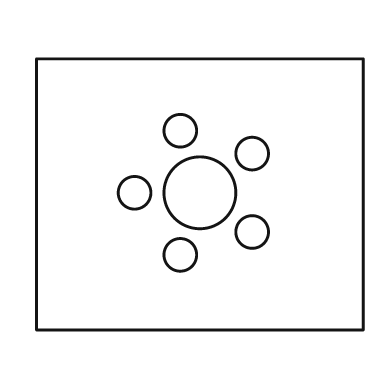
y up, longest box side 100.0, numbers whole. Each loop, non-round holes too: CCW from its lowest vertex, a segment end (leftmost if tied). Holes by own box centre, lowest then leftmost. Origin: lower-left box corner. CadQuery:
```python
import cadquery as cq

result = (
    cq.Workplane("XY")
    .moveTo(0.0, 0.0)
    .lineTo(100.0, 0.0)
    .lineTo(100.0, 83.0)
    .lineTo(0.0, 83.0)
    .close()
    .moveTo(44.0, 23.0)
    .circle(5.0)
    .moveTo(66.0, 30.0)
    .circle(5.0)
    .moveTo(30.0, 42.0)
    .circle(5.0)
    .moveTo(50.0, 42.0)
    .circle(11.0)
    .moveTo(66.0, 54.0)
    .circle(5.0)
    .moveTo(44.0, 61.0)
    .circle(5.0)
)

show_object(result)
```